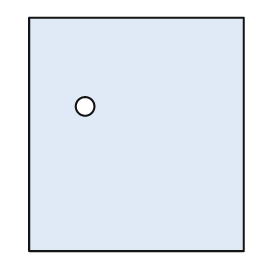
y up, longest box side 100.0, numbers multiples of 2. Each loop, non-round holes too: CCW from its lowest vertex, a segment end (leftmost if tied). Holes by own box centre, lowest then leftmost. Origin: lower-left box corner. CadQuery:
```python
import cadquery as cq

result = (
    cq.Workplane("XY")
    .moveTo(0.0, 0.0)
    .lineTo(92.0, 0.0)
    .lineTo(92.0, 100.0)
    .lineTo(0.0, 100.0)
    .close()
    .moveTo(24.0, 62.0)
    .circle(4.0)
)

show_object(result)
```